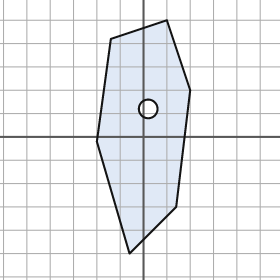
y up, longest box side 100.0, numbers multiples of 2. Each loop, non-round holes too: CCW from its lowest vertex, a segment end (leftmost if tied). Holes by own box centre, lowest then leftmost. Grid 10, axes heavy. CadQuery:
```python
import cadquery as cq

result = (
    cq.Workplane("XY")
    .moveTo(-6.0, -50.0)
    .lineTo(14.0, -30.0)
    .lineTo(20.0, 20.0)
    .lineTo(10.0, 50.0)
    .lineTo(-14.0, 42.0)
    .lineTo(-20.0, -2.0)
    .close()
    .moveTo(2.0, 12.0)
    .circle(4.0)
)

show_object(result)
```